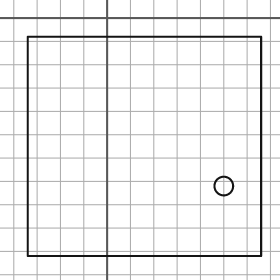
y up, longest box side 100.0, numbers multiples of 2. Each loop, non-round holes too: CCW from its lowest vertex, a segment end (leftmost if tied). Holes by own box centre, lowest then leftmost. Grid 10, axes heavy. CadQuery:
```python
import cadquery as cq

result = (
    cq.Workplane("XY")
    .moveTo(-34.0, -102.0)
    .lineTo(66.0, -102.0)
    .lineTo(66.0, -8.0)
    .lineTo(-34.0, -8.0)
    .close()
    .moveTo(50.0, -72.0)
    .circle(4.0)
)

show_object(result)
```